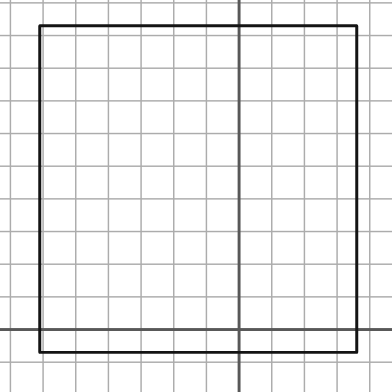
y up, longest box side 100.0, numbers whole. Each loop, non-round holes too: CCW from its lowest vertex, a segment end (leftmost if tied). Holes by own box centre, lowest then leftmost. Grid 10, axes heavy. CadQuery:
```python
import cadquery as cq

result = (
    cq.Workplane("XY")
    .moveTo(-61.0, -7.0)
    .lineTo(36.0, -7.0)
    .lineTo(36.0, 93.0)
    .lineTo(-61.0, 93.0)
    .close()
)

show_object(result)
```